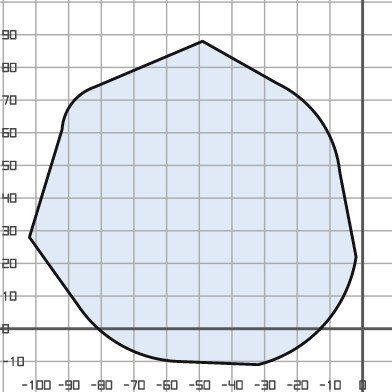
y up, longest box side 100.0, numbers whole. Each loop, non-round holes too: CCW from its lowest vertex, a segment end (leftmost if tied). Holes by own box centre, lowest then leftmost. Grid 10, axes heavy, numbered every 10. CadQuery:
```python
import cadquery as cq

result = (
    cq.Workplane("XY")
    .moveTo(-32.0, -11.0)
    .threePointArc((-12.0, 1.0), (-2.0, 22.0))
    .lineTo(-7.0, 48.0)
    .threePointArc((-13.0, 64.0), (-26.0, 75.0))
    .lineTo(-49.0, 88.0)
    .lineTo(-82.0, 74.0)
    .threePointArc((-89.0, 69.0), (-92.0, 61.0))
    .lineTo(-102.0, 28.0)
    .lineTo(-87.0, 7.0)
    .threePointArc((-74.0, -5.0), (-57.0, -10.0))
    .close()
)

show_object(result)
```